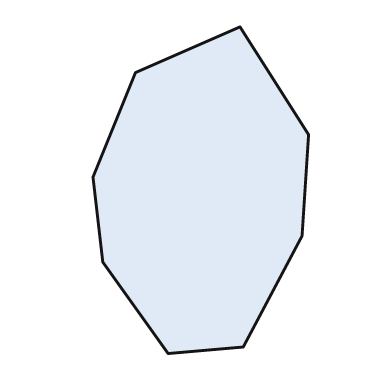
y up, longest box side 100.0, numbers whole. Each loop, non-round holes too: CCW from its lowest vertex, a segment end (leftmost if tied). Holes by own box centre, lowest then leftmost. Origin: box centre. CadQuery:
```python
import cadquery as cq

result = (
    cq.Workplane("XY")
    .moveTo(-10.0, -50.0)
    .lineTo(13.0, -48.0)
    .lineTo(31.0, -14.0)
    .lineTo(33.0, 17.0)
    .lineTo(12.0, 50.0)
    .lineTo(-20.0, 36.0)
    .lineTo(-33.0, 4.0)
    .lineTo(-30.0, -22.0)
    .close()
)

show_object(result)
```